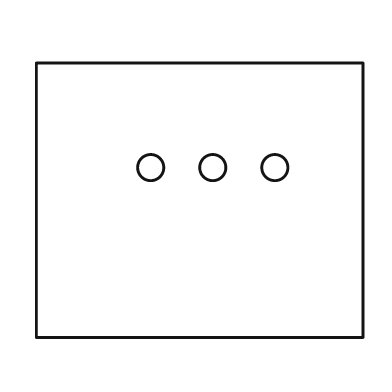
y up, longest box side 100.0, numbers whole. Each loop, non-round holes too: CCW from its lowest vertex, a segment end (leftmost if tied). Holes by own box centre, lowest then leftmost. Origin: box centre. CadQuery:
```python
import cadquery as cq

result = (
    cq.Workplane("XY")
    .moveTo(-50.0, -42.0)
    .lineTo(50.0, -42.0)
    .lineTo(50.0, 42.0)
    .lineTo(-50.0, 42.0)
    .close()
    .moveTo(-15.0, 10.0)
    .circle(4.0)
    .moveTo(4.0, 10.0)
    .circle(4.0)
    .moveTo(23.0, 10.0)
    .circle(4.0)
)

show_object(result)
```